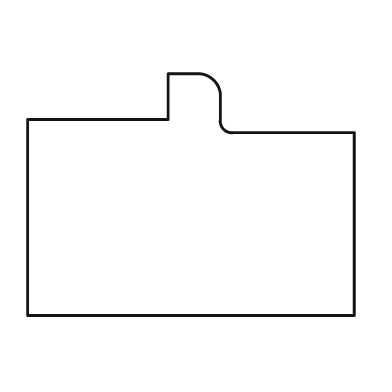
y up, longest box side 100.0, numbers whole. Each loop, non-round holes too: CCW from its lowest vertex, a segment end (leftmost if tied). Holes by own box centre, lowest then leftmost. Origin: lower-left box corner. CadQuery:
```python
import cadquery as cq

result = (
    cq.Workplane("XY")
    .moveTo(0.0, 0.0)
    .lineTo(100.0, 0.0)
    .lineTo(100.0, 56.0)
    .lineTo(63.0, 56.0)
    .threePointArc((60.0, 57.0), (59.0, 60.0))
    .lineTo(59.0, 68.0)
    .threePointArc((57.0, 72.0), (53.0, 74.0))
    .lineTo(43.0, 74.0)
    .lineTo(43.0, 60.0)
    .lineTo(0.0, 60.0)
    .close()
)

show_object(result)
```